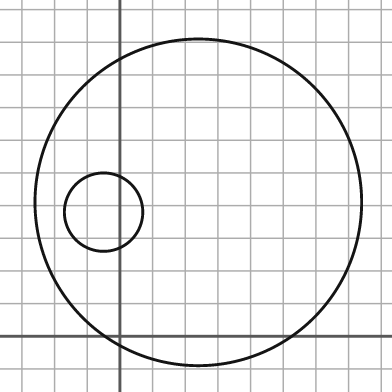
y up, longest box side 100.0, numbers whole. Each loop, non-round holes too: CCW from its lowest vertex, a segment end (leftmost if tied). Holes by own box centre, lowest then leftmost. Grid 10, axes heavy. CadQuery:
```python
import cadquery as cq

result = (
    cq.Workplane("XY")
    .moveTo(24.0, 41.0)
    .circle(50.0)
    .moveTo(-5.0, 38.0)
    .circle(12.0)
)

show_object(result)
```